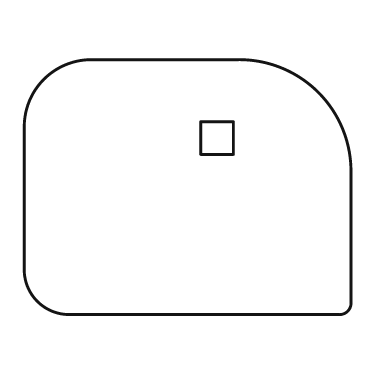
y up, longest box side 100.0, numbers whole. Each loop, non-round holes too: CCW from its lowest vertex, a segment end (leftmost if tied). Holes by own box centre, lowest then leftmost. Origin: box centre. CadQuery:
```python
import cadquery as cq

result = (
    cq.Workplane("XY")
    .moveTo(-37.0, -39.0)
    .lineTo(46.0, -39.0)
    .threePointArc((49.0, -38.0), (50.0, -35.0))
    .lineTo(50.0, 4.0)
    .threePointArc((40.0, 29.0), (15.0, 39.0))
    .lineTo(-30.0, 39.0)
    .threePointArc((-44.0, 33.0), (-50.0, 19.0))
    .lineTo(-50.0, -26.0)
    .threePointArc((-46.0, -35.0), (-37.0, -39.0))
    .close()
    .moveTo(4.0, 10.0)
    .lineTo(14.0, 10.0)
    .lineTo(14.0, 20.0)
    .lineTo(4.0, 20.0)
    .close()
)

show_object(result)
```